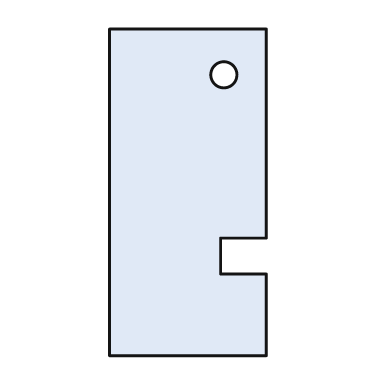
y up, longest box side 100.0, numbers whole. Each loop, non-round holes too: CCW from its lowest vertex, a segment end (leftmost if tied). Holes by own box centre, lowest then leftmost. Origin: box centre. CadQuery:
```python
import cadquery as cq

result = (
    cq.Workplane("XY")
    .moveTo(-24.0, -50.0)
    .lineTo(24.0, -50.0)
    .lineTo(24.0, -25.0)
    .lineTo(10.0, -25.0)
    .lineTo(10.0, -14.0)
    .lineTo(24.0, -14.0)
    .lineTo(24.0, 50.0)
    .lineTo(-24.0, 50.0)
    .close()
    .moveTo(11.0, 36.0)
    .circle(4.0)
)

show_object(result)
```